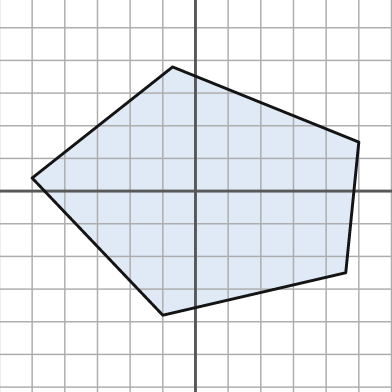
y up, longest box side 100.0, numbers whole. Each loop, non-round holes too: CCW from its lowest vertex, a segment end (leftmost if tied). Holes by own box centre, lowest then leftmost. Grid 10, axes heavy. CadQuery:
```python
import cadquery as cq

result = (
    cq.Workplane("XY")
    .moveTo(-10.0, -38.0)
    .lineTo(46.0, -25.0)
    .lineTo(50.0, 15.0)
    .lineTo(-7.0, 38.0)
    .lineTo(-50.0, 4.0)
    .close()
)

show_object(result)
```